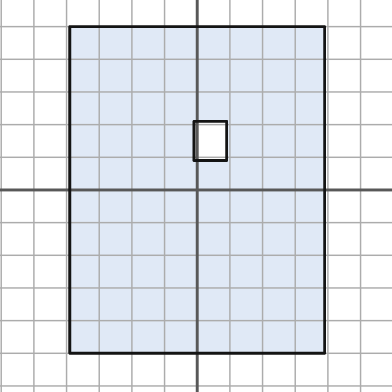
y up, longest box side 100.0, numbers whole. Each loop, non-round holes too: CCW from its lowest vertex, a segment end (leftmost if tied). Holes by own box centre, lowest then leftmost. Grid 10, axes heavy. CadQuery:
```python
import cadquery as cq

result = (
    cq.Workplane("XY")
    .moveTo(-39.0, -50.0)
    .lineTo(39.0, -50.0)
    .lineTo(39.0, 50.0)
    .lineTo(-39.0, 50.0)
    .close()
    .moveTo(-1.0, 9.0)
    .lineTo(9.0, 9.0)
    .lineTo(9.0, 21.0)
    .lineTo(-1.0, 21.0)
    .close()
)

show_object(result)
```